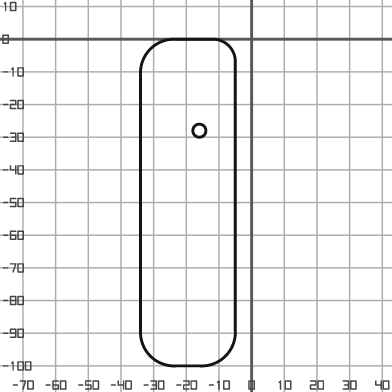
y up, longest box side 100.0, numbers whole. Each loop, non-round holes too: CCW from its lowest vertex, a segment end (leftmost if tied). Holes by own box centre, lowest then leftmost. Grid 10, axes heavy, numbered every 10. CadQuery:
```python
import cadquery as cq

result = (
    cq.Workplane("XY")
    .moveTo(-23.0, -100.0)
    .lineTo(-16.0, -100.0)
    .threePointArc((-8.0, -97.0), (-5.0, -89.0))
    .lineTo(-5.0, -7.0)
    .threePointArc((-7.0, -2.0), (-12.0, 0.0))
    .lineTo(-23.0, 0.0)
    .threePointArc((-31.0, -3.0), (-34.0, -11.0))
    .lineTo(-34.0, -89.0)
    .threePointArc((-31.0, -97.0), (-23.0, -100.0))
    .close()
    .moveTo(-16.0, -28.0)
    .circle(2.0)
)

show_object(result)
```